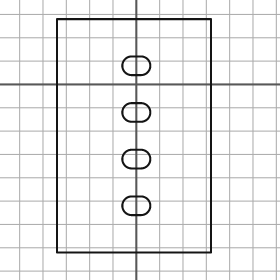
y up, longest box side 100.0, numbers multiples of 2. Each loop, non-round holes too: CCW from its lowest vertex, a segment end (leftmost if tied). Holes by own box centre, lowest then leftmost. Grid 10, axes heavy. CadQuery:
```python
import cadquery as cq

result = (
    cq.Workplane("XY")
    .moveTo(-34.0, -72.0)
    .lineTo(32.0, -72.0)
    .lineTo(32.0, 28.0)
    .lineTo(-34.0, 28.0)
    .close()
    .moveTo(-2.0, -56.0)
    .lineTo(2.0, -56.0)
    .threePointArc((6.0, -52.0), (2.0, -48.0))
    .lineTo(-2.0, -48.0)
    .threePointArc((-6.0, -52.0), (-2.0, -56.0))
    .close()
    .moveTo(-2.0, -36.0)
    .lineTo(2.0, -36.0)
    .threePointArc((6.0, -32.0), (2.0, -28.0))
    .lineTo(-2.0, -28.0)
    .threePointArc((-6.0, -32.0), (-2.0, -36.0))
    .close()
    .moveTo(-2.0, -16.0)
    .lineTo(2.0, -16.0)
    .threePointArc((6.0, -12.0), (2.0, -8.0))
    .lineTo(-2.0, -8.0)
    .threePointArc((-6.0, -12.0), (-2.0, -16.0))
    .close()
    .moveTo(-2.0, 4.0)
    .lineTo(2.0, 4.0)
    .threePointArc((6.0, 8.0), (2.0, 12.0))
    .lineTo(-2.0, 12.0)
    .threePointArc((-6.0, 8.0), (-2.0, 4.0))
    .close()
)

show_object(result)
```